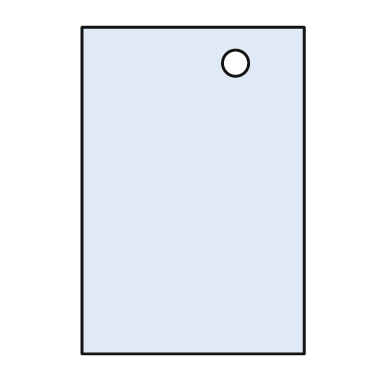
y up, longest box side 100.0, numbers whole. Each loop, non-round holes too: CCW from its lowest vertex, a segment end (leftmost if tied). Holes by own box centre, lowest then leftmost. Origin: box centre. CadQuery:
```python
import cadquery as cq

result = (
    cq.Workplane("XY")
    .moveTo(-34.0, -50.0)
    .lineTo(34.0, -50.0)
    .lineTo(34.0, 50.0)
    .lineTo(-34.0, 50.0)
    .close()
    .moveTo(13.0, 39.0)
    .circle(4.0)
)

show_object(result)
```